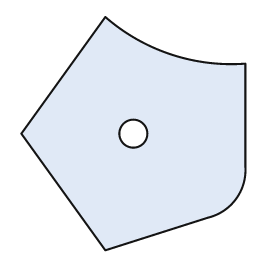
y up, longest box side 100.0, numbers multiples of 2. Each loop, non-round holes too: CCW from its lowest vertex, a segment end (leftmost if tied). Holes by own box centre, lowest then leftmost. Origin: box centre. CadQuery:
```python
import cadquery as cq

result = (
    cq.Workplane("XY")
    .moveTo(-12.0, -50.0)
    .lineTo(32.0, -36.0)
    .threePointArc((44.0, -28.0), (48.0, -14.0))
    .lineTo(48.0, 30.0)
    .threePointArc((16.0, 34.0), (-12.0, 50.0))
    .lineTo(-48.0, 0.0)
    .close()
    .moveTo(0.0, 0.0)
    .circle(6.0)
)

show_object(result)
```